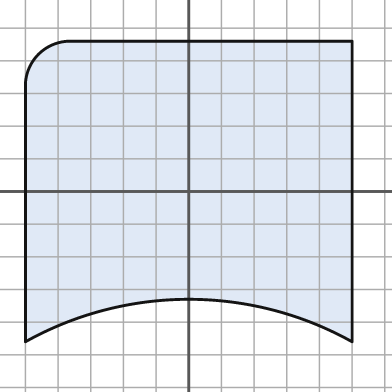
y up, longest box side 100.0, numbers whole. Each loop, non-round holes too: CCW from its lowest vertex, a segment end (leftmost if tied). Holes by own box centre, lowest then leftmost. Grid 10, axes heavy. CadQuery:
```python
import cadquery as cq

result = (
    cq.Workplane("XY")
    .moveTo(-50.0, -46.0)
    .threePointArc((0.0, -33.0), (50.0, -46.0))
    .lineTo(50.0, 46.0)
    .lineTo(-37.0, 46.0)
    .threePointArc((-46.0, 42.0), (-50.0, 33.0))
    .close()
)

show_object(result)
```